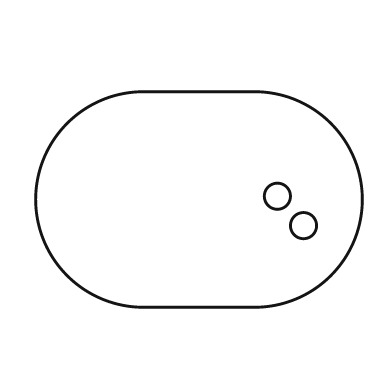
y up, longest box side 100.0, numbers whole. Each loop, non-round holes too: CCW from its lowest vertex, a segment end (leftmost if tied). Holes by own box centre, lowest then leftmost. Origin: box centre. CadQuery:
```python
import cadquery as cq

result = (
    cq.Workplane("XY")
    .moveTo(-17.0, -33.0)
    .lineTo(17.0, -33.0)
    .threePointArc((50.0, 0.0), (17.0, 33.0))
    .lineTo(-17.0, 33.0)
    .threePointArc((-50.0, 0.0), (-17.0, -33.0))
    .close()
    .moveTo(32.0, -8.0)
    .circle(4.0)
    .moveTo(24.0, 1.0)
    .circle(4.0)
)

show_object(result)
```